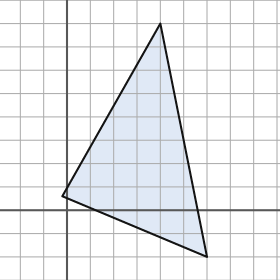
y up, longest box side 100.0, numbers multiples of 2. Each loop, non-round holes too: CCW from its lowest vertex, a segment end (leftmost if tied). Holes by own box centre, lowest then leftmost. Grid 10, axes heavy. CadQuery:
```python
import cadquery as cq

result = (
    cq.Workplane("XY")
    .moveTo(60.0, -20.0)
    .lineTo(40.0, 80.0)
    .lineTo(-2.0, 6.0)
    .close()
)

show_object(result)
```